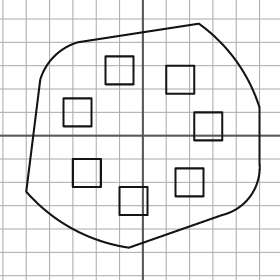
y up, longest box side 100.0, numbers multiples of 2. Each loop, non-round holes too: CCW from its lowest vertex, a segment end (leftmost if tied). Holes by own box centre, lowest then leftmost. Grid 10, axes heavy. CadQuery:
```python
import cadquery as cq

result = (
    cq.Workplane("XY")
    .moveTo(-6.0, -48.0)
    .lineTo(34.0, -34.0)
    .threePointArc((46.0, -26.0), (50.0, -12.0))
    .lineTo(50.0, 12.0)
    .threePointArc((40.0, 32.0), (24.0, 48.0))
    .lineTo(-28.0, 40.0)
    .threePointArc((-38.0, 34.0), (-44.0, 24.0))
    .lineTo(-50.0, -24.0)
    .threePointArc((-30.0, -40.0), (-6.0, -48.0))
    .close()
    .moveTo(-10.0, -34.0)
    .lineTo(2.0, -34.0)
    .lineTo(2.0, -22.0)
    .lineTo(-10.0, -22.0)
    .close()
    .moveTo(14.0, -26.0)
    .lineTo(26.0, -26.0)
    .lineTo(26.0, -14.0)
    .lineTo(14.0, -14.0)
    .close()
    .moveTo(-30.0, -22.0)
    .lineTo(-18.0, -22.0)
    .lineTo(-18.0, -10.0)
    .lineTo(-30.0, -10.0)
    .close()
    .moveTo(22.0, -2.0)
    .lineTo(34.0, -2.0)
    .lineTo(34.0, 10.0)
    .lineTo(22.0, 10.0)
    .close()
    .moveTo(-34.0, 4.0)
    .lineTo(-22.0, 4.0)
    .lineTo(-22.0, 16.0)
    .lineTo(-34.0, 16.0)
    .close()
    .moveTo(10.0, 18.0)
    .lineTo(22.0, 18.0)
    .lineTo(22.0, 30.0)
    .lineTo(10.0, 30.0)
    .close()
    .moveTo(-16.0, 22.0)
    .lineTo(-4.0, 22.0)
    .lineTo(-4.0, 34.0)
    .lineTo(-16.0, 34.0)
    .close()
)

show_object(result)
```